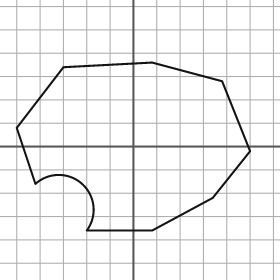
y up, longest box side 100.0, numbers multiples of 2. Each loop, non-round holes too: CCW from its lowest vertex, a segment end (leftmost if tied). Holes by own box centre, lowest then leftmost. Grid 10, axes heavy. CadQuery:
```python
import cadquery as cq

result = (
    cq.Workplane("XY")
    .moveTo(-20.0, -36.0)
    .lineTo(8.0, -36.0)
    .lineTo(34.0, -22.0)
    .lineTo(50.0, -2.0)
    .lineTo(38.0, 28.0)
    .lineTo(8.0, 36.0)
    .lineTo(-30.0, 34.0)
    .lineTo(-50.0, 8.0)
    .lineTo(-42.0, -16.0)
    .threePointArc((-22.0, -16.0), (-20.0, -36.0))
    .close()
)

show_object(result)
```